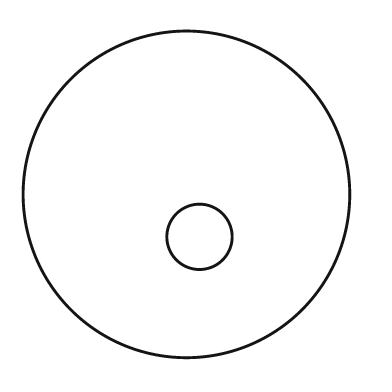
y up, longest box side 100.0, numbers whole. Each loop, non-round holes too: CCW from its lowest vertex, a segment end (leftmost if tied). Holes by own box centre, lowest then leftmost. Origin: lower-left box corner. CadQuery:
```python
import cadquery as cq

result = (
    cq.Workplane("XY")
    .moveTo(50.0, 50.0)
    .circle(50.0)
    .moveTo(54.0, 37.0)
    .circle(10.0)
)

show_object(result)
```